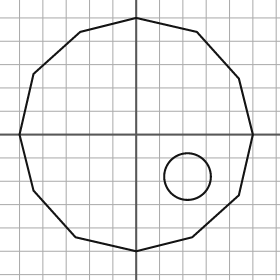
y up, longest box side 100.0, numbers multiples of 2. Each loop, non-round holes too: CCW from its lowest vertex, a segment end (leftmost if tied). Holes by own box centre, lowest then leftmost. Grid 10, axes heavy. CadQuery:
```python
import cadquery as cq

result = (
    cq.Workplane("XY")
    .moveTo(0.0, -50.0)
    .lineTo(24.0, -44.0)
    .lineTo(44.0, -26.0)
    .lineTo(50.0, 0.0)
    .lineTo(44.0, 24.0)
    .lineTo(26.0, 44.0)
    .lineTo(0.0, 50.0)
    .lineTo(-24.0, 44.0)
    .lineTo(-44.0, 26.0)
    .lineTo(-50.0, 0.0)
    .lineTo(-44.0, -24.0)
    .lineTo(-26.0, -44.0)
    .close()
    .moveTo(22.0, -18.0)
    .circle(10.0)
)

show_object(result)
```